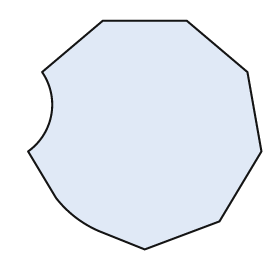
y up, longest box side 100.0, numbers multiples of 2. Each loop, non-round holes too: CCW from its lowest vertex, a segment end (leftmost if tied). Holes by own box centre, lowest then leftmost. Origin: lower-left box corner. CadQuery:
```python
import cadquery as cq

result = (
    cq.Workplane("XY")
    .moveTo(50.0, 0.0)
    .lineTo(82.0, 12.0)
    .lineTo(100.0, 42.0)
    .lineTo(94.0, 76.0)
    .lineTo(68.0, 98.0)
    .lineTo(32.0, 98.0)
    .lineTo(6.0, 76.0)
    .threePointArc((10.0, 58.0), (0.0, 42.0))
    .lineTo(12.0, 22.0)
    .threePointArc((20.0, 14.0), (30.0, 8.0))
    .close()
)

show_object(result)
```